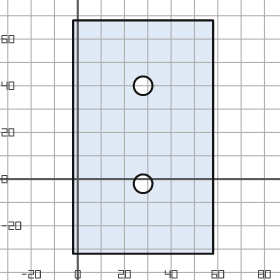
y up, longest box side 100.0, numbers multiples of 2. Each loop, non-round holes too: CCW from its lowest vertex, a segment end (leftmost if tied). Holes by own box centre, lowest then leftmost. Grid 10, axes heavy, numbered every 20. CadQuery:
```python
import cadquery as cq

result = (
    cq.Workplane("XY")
    .moveTo(-2.0, -32.0)
    .lineTo(58.0, -32.0)
    .lineTo(58.0, 68.0)
    .lineTo(-2.0, 68.0)
    .close()
    .moveTo(28.0, -2.0)
    .circle(4.0)
    .moveTo(28.0, 40.0)
    .circle(4.0)
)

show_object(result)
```